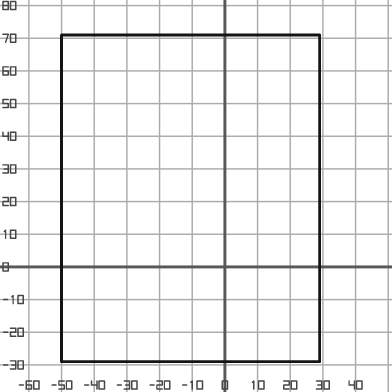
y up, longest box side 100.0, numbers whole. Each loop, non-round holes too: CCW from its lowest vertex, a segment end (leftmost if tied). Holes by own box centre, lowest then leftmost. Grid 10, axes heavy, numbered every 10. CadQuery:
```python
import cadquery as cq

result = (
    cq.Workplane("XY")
    .moveTo(-50.0, -29.0)
    .lineTo(29.0, -29.0)
    .lineTo(29.0, 71.0)
    .lineTo(-50.0, 71.0)
    .close()
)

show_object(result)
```